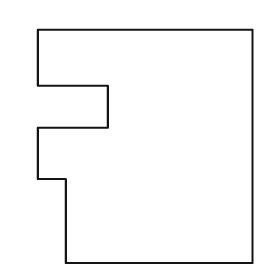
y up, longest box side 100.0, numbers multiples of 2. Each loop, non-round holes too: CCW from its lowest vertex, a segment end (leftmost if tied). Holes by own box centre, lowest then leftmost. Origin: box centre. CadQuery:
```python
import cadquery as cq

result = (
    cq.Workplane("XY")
    .moveTo(-34.0, -50.0)
    .lineTo(46.0, -50.0)
    .lineTo(46.0, 50.0)
    .lineTo(-46.0, 50.0)
    .lineTo(-46.0, 26.0)
    .lineTo(-16.0, 26.0)
    .lineTo(-16.0, 8.0)
    .lineTo(-46.0, 8.0)
    .lineTo(-46.0, -14.0)
    .lineTo(-34.0, -14.0)
    .close()
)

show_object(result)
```